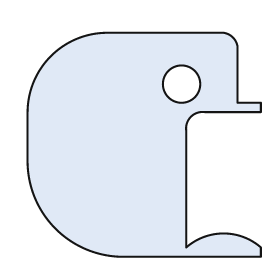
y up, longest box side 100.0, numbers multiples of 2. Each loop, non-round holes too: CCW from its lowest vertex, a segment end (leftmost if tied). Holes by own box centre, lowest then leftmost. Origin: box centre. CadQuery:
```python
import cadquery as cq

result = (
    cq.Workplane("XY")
    .moveTo(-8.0, -48.0)
    .lineTo(50.0, -48.0)
    .lineTo(50.0, -44.0)
    .threePointArc((34.0, -38.0), (18.0, -44.0))
    .lineTo(18.0, 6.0)
    .threePointArc((20.0, 12.0), (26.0, 14.0))
    .lineTo(50.0, 14.0)
    .lineTo(50.0, 18.0)
    .lineTo(40.0, 18.0)
    .lineTo(40.0, 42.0)
    .threePointArc((38.0, 46.0), (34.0, 48.0))
    .lineTo(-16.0, 48.0)
    .threePointArc((-40.0, 38.0), (-50.0, 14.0))
    .lineTo(-50.0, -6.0)
    .threePointArc((-38.0, -36.0), (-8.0, -48.0))
    .close()
    .moveTo(16.0, 26.0)
    .circle(8.0)
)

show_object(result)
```